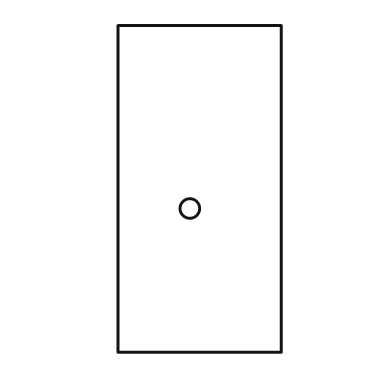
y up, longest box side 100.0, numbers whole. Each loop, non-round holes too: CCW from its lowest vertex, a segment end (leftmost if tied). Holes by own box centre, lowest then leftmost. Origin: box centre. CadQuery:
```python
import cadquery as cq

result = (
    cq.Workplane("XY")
    .moveTo(-25.0, -50.0)
    .lineTo(25.0, -50.0)
    .lineTo(25.0, 50.0)
    .lineTo(-25.0, 50.0)
    .close()
    .moveTo(-3.0, -6.0)
    .circle(3.0)
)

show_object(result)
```